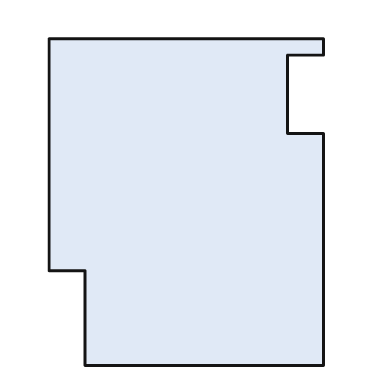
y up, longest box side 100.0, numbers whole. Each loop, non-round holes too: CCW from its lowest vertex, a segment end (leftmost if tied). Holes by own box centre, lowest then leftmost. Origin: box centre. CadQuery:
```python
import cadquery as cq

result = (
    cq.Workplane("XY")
    .moveTo(-31.0, -50.0)
    .lineTo(42.0, -50.0)
    .lineTo(42.0, 21.0)
    .lineTo(31.0, 21.0)
    .lineTo(31.0, 45.0)
    .lineTo(42.0, 45.0)
    .lineTo(42.0, 50.0)
    .lineTo(-42.0, 50.0)
    .lineTo(-42.0, -21.0)
    .lineTo(-31.0, -21.0)
    .close()
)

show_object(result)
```